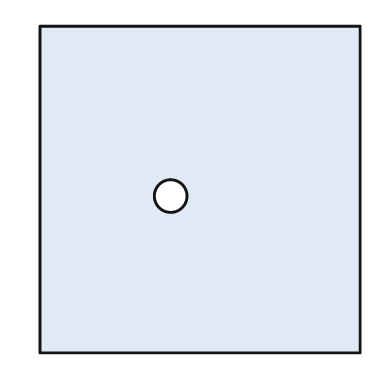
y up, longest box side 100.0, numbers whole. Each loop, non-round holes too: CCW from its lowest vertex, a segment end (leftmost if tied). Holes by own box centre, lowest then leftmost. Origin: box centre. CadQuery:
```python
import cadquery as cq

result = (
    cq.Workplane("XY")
    .moveTo(-49.0, -50.0)
    .lineTo(49.0, -50.0)
    .lineTo(49.0, 50.0)
    .lineTo(-49.0, 50.0)
    .close()
    .moveTo(-9.0, -2.0)
    .circle(5.0)
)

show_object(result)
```